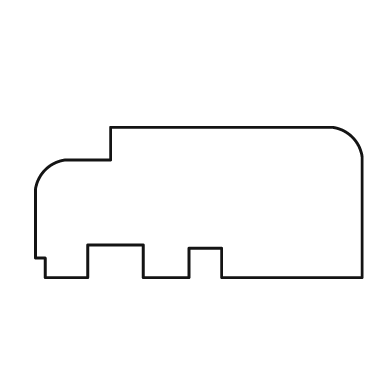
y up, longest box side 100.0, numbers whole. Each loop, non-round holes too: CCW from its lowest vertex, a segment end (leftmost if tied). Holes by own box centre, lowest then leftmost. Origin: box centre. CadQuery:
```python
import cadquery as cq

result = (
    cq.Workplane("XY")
    .moveTo(-47.0, -23.0)
    .lineTo(-34.0, -23.0)
    .lineTo(-34.0, -13.0)
    .lineTo(-17.0, -13.0)
    .lineTo(-17.0, -23.0)
    .lineTo(-3.0, -23.0)
    .lineTo(-3.0, -14.0)
    .lineTo(7.0, -14.0)
    .lineTo(7.0, -23.0)
    .lineTo(50.0, -23.0)
    .lineTo(50.0, 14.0)
    .threePointArc((47.0, 20.0), (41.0, 23.0))
    .lineTo(-27.0, 23.0)
    .lineTo(-27.0, 13.0)
    .lineTo(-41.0, 13.0)
    .threePointArc((-47.0, 10.0), (-50.0, 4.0))
    .lineTo(-50.0, -17.0)
    .lineTo(-47.0, -17.0)
    .close()
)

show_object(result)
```